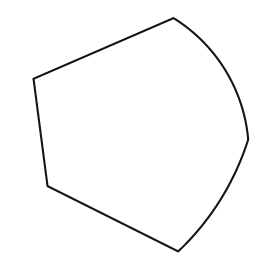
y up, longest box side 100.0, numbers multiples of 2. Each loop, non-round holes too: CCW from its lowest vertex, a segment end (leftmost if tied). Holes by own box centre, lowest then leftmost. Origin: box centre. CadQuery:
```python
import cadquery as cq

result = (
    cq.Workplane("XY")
    .moveTo(16.0, -50.0)
    .threePointArc((34.0, -28.0), (46.0, -2.0))
    .threePointArc((36.0, 28.0), (14.0, 50.0))
    .lineTo(-46.0, 24.0)
    .lineTo(-40.0, -22.0)
    .close()
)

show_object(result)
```